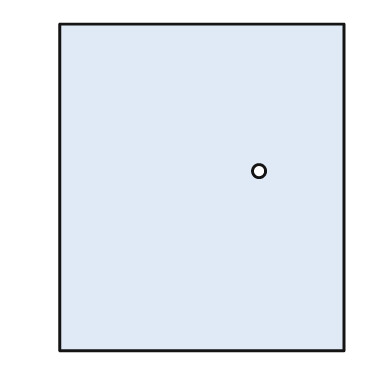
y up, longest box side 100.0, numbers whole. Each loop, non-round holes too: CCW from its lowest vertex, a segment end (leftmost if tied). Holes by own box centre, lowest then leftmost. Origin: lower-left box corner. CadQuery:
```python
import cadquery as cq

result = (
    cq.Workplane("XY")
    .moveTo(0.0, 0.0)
    .lineTo(87.0, 0.0)
    .lineTo(87.0, 100.0)
    .lineTo(0.0, 100.0)
    .close()
    .moveTo(61.0, 55.0)
    .circle(2.0)
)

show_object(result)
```